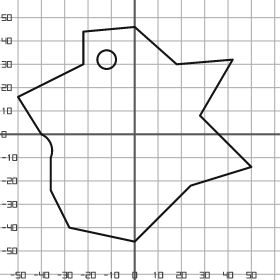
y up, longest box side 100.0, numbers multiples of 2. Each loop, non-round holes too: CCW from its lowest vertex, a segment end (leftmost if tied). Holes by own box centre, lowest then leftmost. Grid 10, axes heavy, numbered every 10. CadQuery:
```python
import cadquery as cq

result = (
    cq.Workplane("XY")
    .moveTo(0.0, -46.0)
    .lineTo(24.0, -22.0)
    .lineTo(50.0, -14.0)
    .lineTo(28.0, 8.0)
    .lineTo(42.0, 32.0)
    .lineTo(18.0, 30.0)
    .lineTo(0.0, 46.0)
    .lineTo(-22.0, 44.0)
    .lineTo(-22.0, 30.0)
    .lineTo(-50.0, 16.0)
    .lineTo(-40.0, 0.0)
    .threePointArc((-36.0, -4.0), (-36.0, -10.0))
    .lineTo(-36.0, -24.0)
    .lineTo(-28.0, -40.0)
    .close()
    .moveTo(-12.0, 32.0)
    .circle(4.0)
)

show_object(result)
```